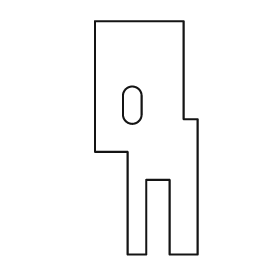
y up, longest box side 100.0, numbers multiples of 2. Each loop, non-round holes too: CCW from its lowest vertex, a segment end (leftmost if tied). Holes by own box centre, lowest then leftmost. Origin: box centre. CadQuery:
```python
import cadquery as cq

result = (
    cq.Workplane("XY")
    .moveTo(-8.0, -50.0)
    .lineTo(0.0, -50.0)
    .lineTo(0.0, -18.0)
    .lineTo(10.0, -18.0)
    .lineTo(10.0, -50.0)
    .lineTo(22.0, -50.0)
    .lineTo(22.0, 8.0)
    .lineTo(16.0, 8.0)
    .lineTo(16.0, 50.0)
    .lineTo(-22.0, 50.0)
    .lineTo(-22.0, -6.0)
    .lineTo(-8.0, -6.0)
    .close()
    .moveTo(-10.0, 10.0)
    .threePointArc((-6.0, 6.0), (-2.0, 10.0))
    .lineTo(-2.0, 18.0)
    .threePointArc((-6.0, 22.0), (-10.0, 18.0))
    .close()
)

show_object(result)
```